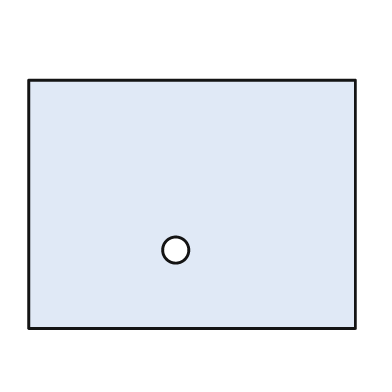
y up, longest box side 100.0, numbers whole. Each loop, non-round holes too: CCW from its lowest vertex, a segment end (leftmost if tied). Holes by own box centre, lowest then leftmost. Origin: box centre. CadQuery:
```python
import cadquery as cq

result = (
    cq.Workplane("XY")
    .moveTo(-50.0, -38.0)
    .lineTo(50.0, -38.0)
    .lineTo(50.0, 38.0)
    .lineTo(-50.0, 38.0)
    .close()
    .moveTo(-5.0, -14.0)
    .circle(4.0)
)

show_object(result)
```